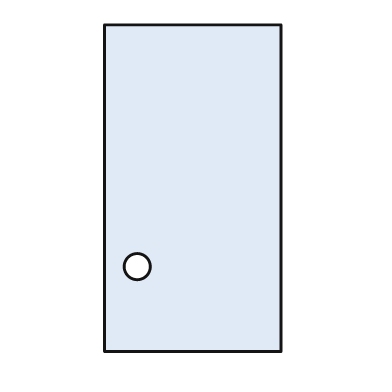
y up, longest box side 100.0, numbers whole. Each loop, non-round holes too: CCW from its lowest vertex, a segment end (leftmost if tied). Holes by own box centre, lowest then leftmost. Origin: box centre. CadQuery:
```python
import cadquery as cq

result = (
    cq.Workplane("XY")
    .moveTo(-27.0, -50.0)
    .lineTo(27.0, -50.0)
    .lineTo(27.0, 50.0)
    .lineTo(-27.0, 50.0)
    .close()
    .moveTo(-17.0, -24.0)
    .circle(4.0)
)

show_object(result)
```